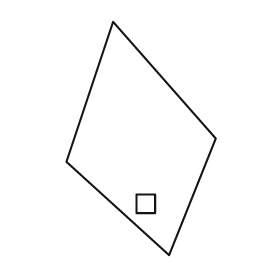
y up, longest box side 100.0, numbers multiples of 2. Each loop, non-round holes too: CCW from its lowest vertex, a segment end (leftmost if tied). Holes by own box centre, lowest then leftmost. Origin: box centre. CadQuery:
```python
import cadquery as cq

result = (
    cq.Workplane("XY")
    .moveTo(12.0, -50.0)
    .lineTo(32.0, 0.0)
    .lineTo(-12.0, 50.0)
    .lineTo(-32.0, -10.0)
    .close()
    .moveTo(-2.0, -32.0)
    .lineTo(6.0, -32.0)
    .lineTo(6.0, -24.0)
    .lineTo(-2.0, -24.0)
    .close()
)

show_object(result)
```